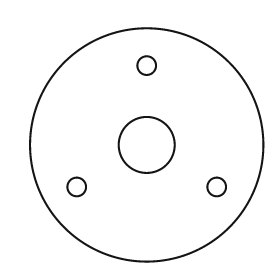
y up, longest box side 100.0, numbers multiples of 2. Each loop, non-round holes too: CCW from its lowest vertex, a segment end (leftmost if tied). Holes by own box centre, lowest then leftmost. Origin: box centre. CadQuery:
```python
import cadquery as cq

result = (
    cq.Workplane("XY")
    .moveTo(0.0, 0.0)
    .circle(50.0)
    .moveTo(-30.0, -18.0)
    .circle(4.0)
    .moveTo(30.0, -18.0)
    .circle(4.0)
    .moveTo(0.0, 0.0)
    .circle(12.0)
    .moveTo(0.0, 34.0)
    .circle(4.0)
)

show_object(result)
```